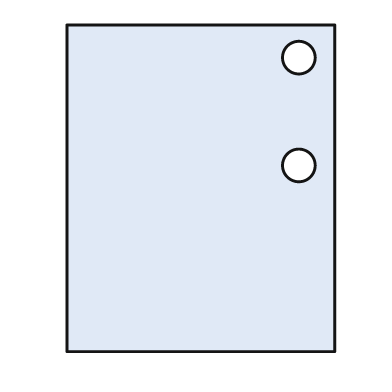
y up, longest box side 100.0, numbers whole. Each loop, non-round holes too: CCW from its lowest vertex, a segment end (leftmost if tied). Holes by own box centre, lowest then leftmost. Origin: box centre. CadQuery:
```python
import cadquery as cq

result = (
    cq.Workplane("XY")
    .moveTo(-41.0, -50.0)
    .lineTo(41.0, -50.0)
    .lineTo(41.0, 50.0)
    .lineTo(-41.0, 50.0)
    .close()
    .moveTo(30.0, 7.0)
    .circle(5.0)
    .moveTo(30.0, 40.0)
    .circle(5.0)
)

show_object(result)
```